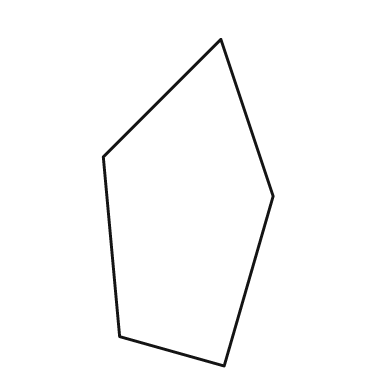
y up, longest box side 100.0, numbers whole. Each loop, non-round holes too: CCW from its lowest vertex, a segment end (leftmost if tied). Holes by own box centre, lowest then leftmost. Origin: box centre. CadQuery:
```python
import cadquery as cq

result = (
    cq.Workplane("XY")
    .moveTo(11.0, -50.0)
    .lineTo(26.0, 2.0)
    .lineTo(10.0, 50.0)
    .lineTo(-26.0, 14.0)
    .lineTo(-21.0, -41.0)
    .close()
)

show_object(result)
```